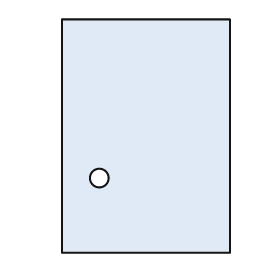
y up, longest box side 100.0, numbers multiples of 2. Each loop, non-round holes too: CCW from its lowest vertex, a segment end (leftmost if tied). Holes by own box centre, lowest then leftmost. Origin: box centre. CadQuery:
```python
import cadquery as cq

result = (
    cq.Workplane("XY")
    .moveTo(-36.0, -50.0)
    .lineTo(36.0, -50.0)
    .lineTo(36.0, 50.0)
    .lineTo(-36.0, 50.0)
    .close()
    .moveTo(-20.0, -18.0)
    .circle(4.0)
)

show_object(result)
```